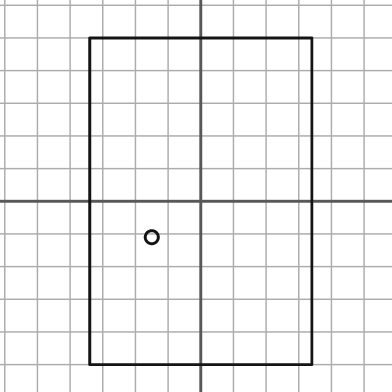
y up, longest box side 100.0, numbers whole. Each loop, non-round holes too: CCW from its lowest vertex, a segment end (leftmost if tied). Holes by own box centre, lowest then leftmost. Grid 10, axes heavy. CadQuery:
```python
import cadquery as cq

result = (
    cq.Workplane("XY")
    .moveTo(-34.0, -50.0)
    .lineTo(34.0, -50.0)
    .lineTo(34.0, 50.0)
    .lineTo(-34.0, 50.0)
    .close()
    .moveTo(-15.0, -11.0)
    .circle(2.0)
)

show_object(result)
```